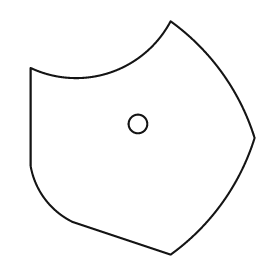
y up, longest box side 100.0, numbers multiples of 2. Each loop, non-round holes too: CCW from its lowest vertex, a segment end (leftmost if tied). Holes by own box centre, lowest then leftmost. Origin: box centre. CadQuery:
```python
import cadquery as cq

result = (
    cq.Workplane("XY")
    .moveTo(12.0, -50.0)
    .threePointArc((34.0, -28.0), (48.0, 0.0))
    .threePointArc((34.0, 28.0), (12.0, 50.0))
    .threePointArc((-14.0, 28.0), (-48.0, 30.0))
    .lineTo(-48.0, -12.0)
    .threePointArc((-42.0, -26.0), (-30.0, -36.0))
    .close()
    .moveTo(-2.0, 6.0)
    .circle(4.0)
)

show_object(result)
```